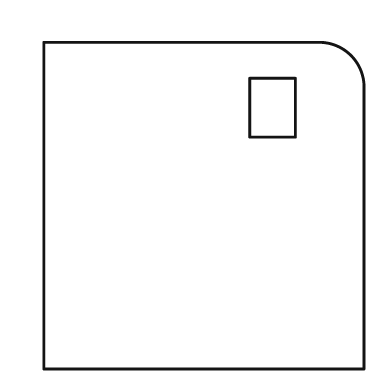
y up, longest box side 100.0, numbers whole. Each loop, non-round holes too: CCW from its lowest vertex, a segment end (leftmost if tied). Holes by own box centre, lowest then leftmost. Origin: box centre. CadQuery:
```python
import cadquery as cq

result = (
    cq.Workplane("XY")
    .moveTo(-49.0, -50.0)
    .lineTo(49.0, -50.0)
    .lineTo(49.0, 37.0)
    .threePointArc((45.0, 46.0), (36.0, 50.0))
    .lineTo(-49.0, 50.0)
    .close()
    .moveTo(14.0, 21.0)
    .lineTo(28.0, 21.0)
    .lineTo(28.0, 39.0)
    .lineTo(14.0, 39.0)
    .close()
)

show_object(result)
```